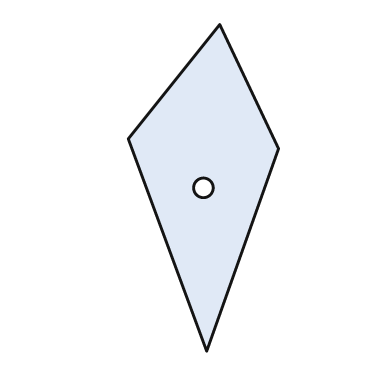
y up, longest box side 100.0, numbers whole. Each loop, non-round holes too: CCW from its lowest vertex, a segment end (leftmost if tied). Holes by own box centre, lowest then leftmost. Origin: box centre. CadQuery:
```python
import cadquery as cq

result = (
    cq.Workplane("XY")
    .moveTo(1.0, -50.0)
    .lineTo(23.0, 12.0)
    .lineTo(5.0, 50.0)
    .lineTo(-23.0, 15.0)
    .close()
    .moveTo(0.0, 0.0)
    .circle(3.0)
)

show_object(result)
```